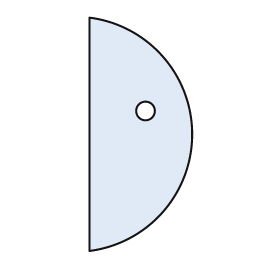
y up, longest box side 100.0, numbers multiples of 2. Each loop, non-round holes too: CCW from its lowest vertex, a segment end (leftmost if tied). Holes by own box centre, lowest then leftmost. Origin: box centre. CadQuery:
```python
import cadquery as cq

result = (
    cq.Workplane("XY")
    .moveTo(-22.0, -50.0)
    .threePointArc((22.0, 0.0), (-22.0, 50.0))
    .close()
    .moveTo(2.0, 10.0)
    .circle(4.0)
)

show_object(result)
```